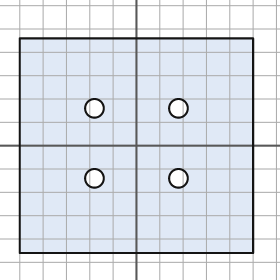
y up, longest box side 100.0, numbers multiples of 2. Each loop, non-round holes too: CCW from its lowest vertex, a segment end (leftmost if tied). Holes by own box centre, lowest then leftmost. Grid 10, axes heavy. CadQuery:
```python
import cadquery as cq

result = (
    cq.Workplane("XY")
    .moveTo(-50.0, -46.0)
    .lineTo(50.0, -46.0)
    .lineTo(50.0, 46.0)
    .lineTo(-50.0, 46.0)
    .close()
    .moveTo(-18.0, -14.0)
    .circle(4.0)
    .moveTo(18.0, -14.0)
    .circle(4.0)
    .moveTo(-18.0, 16.0)
    .circle(4.0)
    .moveTo(18.0, 16.0)
    .circle(4.0)
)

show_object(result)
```